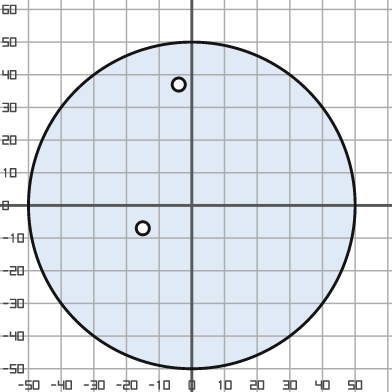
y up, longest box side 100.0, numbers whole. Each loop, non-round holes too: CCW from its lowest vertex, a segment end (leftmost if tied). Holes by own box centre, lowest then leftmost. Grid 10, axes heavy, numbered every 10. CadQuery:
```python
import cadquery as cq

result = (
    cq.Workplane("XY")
    .moveTo(0.0, 0.0)
    .circle(50.0)
    .moveTo(-15.0, -7.0)
    .circle(2.0)
    .moveTo(-4.0, 37.0)
    .circle(2.0)
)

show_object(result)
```